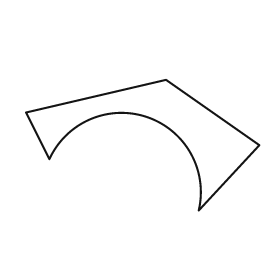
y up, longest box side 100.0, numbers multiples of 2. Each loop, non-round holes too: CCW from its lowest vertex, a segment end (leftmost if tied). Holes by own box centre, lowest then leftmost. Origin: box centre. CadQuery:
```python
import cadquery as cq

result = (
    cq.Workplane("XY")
    .moveTo(24.0, -28.0)
    .lineTo(50.0, 0.0)
    .lineTo(10.0, 28.0)
    .lineTo(-50.0, 14.0)
    .lineTo(-40.0, -6.0)
    .threePointArc((2.0, 12.0), (24.0, -28.0))
    .close()
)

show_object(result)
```